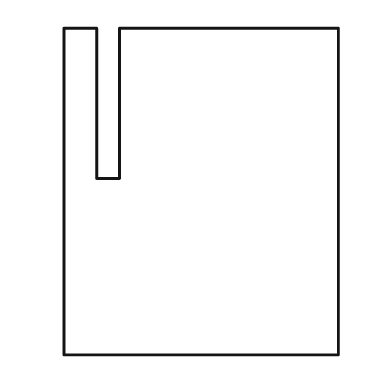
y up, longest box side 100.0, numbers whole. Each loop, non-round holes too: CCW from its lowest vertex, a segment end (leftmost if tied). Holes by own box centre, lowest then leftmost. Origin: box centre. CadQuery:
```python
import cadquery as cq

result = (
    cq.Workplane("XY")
    .moveTo(-42.0, -50.0)
    .lineTo(42.0, -50.0)
    .lineTo(42.0, 50.0)
    .lineTo(-25.0, 50.0)
    .lineTo(-25.0, 4.0)
    .lineTo(-32.0, 4.0)
    .lineTo(-32.0, 50.0)
    .lineTo(-42.0, 50.0)
    .close()
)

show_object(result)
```